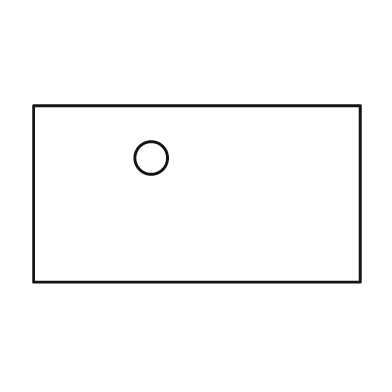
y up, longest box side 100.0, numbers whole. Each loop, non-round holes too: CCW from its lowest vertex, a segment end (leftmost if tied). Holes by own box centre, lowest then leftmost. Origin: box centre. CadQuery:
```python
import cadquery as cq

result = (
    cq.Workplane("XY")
    .moveTo(-50.0, -27.0)
    .lineTo(50.0, -27.0)
    .lineTo(50.0, 27.0)
    .lineTo(-50.0, 27.0)
    .close()
    .moveTo(-14.0, 11.0)
    .circle(5.0)
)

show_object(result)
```